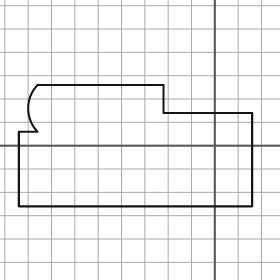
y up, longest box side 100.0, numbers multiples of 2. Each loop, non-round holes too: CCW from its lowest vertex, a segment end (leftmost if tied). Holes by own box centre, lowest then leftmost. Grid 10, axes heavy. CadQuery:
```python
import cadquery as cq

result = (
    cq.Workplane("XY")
    .moveTo(-84.0, -26.0)
    .lineTo(16.0, -26.0)
    .lineTo(16.0, 14.0)
    .lineTo(-22.0, 14.0)
    .lineTo(-22.0, 26.0)
    .lineTo(-76.0, 26.0)
    .threePointArc((-80.0, 16.0), (-76.0, 6.0))
    .lineTo(-84.0, 6.0)
    .close()
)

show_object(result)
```